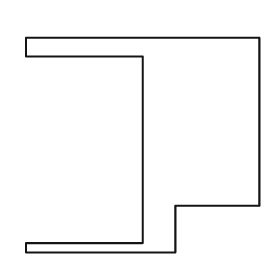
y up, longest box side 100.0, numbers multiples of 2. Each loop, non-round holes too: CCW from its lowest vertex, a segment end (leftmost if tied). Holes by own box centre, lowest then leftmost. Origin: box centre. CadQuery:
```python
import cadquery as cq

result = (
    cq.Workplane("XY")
    .moveTo(-50.0, -46.0)
    .lineTo(14.0, -46.0)
    .lineTo(14.0, -26.0)
    .lineTo(50.0, -26.0)
    .lineTo(50.0, 46.0)
    .lineTo(-50.0, 46.0)
    .lineTo(-50.0, 38.0)
    .lineTo(0.0, 38.0)
    .lineTo(0.0, -42.0)
    .lineTo(-50.0, -42.0)
    .close()
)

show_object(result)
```